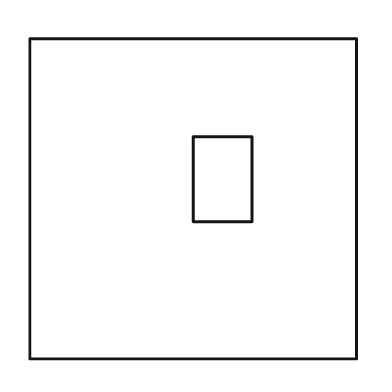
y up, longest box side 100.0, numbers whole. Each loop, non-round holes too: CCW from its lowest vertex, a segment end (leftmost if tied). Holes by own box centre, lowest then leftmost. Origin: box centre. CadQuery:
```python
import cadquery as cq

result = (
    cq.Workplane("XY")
    .moveTo(-50.0, -49.0)
    .lineTo(50.0, -49.0)
    .lineTo(50.0, 49.0)
    .lineTo(-50.0, 49.0)
    .close()
    .moveTo(0.0, -7.0)
    .lineTo(18.0, -7.0)
    .lineTo(18.0, 19.0)
    .lineTo(0.0, 19.0)
    .close()
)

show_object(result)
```